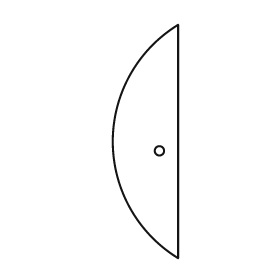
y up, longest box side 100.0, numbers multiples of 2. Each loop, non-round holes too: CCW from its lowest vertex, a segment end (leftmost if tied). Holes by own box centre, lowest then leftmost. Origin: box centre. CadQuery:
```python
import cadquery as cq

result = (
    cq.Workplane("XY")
    .moveTo(14.0, -50.0)
    .lineTo(14.0, 50.0)
    .threePointArc((-14.0, 0.0), (14.0, -50.0))
    .close()
    .moveTo(6.0, -4.0)
    .circle(2.0)
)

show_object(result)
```